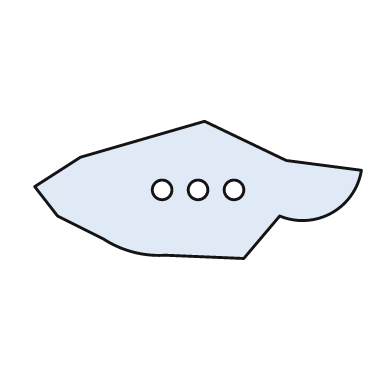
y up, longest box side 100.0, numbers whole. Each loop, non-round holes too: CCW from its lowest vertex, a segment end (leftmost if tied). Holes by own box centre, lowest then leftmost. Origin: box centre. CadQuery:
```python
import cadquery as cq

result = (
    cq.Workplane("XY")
    .moveTo(14.0, -21.0)
    .lineTo(25.0, -8.0)
    .threePointArc((41.0, -7.0), (50.0, 6.0))
    .lineTo(27.0, 9.0)
    .lineTo(2.0, 21.0)
    .lineTo(-36.0, 10.0)
    .lineTo(-50.0, 1.0)
    .lineTo(-43.0, -8.0)
    .lineTo(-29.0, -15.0)
    .threePointArc((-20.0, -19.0), (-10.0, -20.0))
    .close()
    .moveTo(-11.0, 0.0)
    .circle(3.0)
    .moveTo(0.0, 0.0)
    .circle(3.0)
    .moveTo(11.0, 0.0)
    .circle(3.0)
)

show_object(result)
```